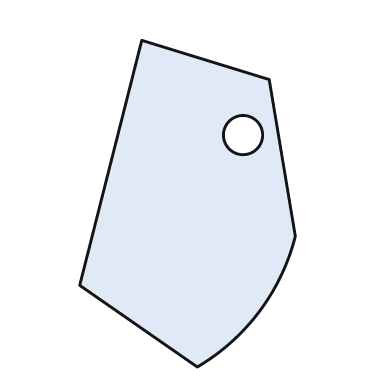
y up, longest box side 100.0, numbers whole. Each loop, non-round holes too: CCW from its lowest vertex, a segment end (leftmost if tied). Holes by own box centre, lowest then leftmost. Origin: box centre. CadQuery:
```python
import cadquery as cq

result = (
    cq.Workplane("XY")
    .moveTo(3.0, -50.0)
    .threePointArc((22.0, -33.0), (33.0, -10.0))
    .lineTo(25.0, 38.0)
    .lineTo(-14.0, 50.0)
    .lineTo(-33.0, -25.0)
    .close()
    .moveTo(17.0, 21.0)
    .circle(6.0)
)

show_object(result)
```